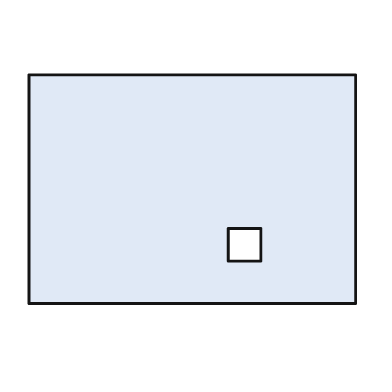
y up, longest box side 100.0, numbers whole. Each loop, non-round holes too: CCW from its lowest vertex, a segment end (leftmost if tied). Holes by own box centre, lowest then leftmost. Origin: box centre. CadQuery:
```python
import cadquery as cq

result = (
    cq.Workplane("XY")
    .moveTo(-50.0, -35.0)
    .lineTo(50.0, -35.0)
    .lineTo(50.0, 35.0)
    .lineTo(-50.0, 35.0)
    .close()
    .moveTo(11.0, -22.0)
    .lineTo(21.0, -22.0)
    .lineTo(21.0, -12.0)
    .lineTo(11.0, -12.0)
    .close()
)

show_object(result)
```